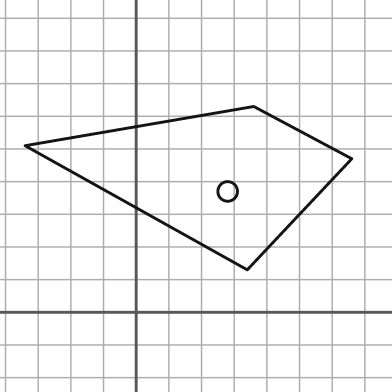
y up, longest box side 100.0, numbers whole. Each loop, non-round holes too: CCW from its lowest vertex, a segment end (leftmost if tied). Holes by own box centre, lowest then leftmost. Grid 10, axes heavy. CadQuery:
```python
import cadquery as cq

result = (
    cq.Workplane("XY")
    .moveTo(34.0, 13.0)
    .lineTo(66.0, 47.0)
    .lineTo(36.0, 63.0)
    .lineTo(-34.0, 51.0)
    .close()
    .moveTo(28.0, 37.0)
    .circle(3.0)
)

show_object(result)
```